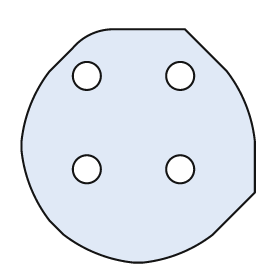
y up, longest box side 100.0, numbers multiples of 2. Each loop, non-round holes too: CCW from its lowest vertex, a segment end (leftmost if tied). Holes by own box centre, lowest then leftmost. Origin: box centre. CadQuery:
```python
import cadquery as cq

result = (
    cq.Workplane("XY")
    .moveTo(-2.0, -50.0)
    .lineTo(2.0, -50.0)
    .threePointArc((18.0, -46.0), (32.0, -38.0))
    .lineTo(50.0, -20.0)
    .lineTo(50.0, 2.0)
    .threePointArc((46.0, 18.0), (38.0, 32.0))
    .lineTo(20.0, 50.0)
    .lineTo(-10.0, 50.0)
    .threePointArc((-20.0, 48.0), (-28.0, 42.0))
    .lineTo(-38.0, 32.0)
    .threePointArc((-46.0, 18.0), (-50.0, 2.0))
    .lineTo(-50.0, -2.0)
    .threePointArc((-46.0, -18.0), (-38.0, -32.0))
    .lineTo(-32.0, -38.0)
    .threePointArc((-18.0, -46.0), (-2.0, -50.0))
    .close()
    .moveTo(-22.0, -10.0)
    .circle(6.0)
    .moveTo(18.0, -10.0)
    .circle(6.0)
    .moveTo(-22.0, 30.0)
    .circle(6.0)
    .moveTo(18.0, 30.0)
    .circle(6.0)
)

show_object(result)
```